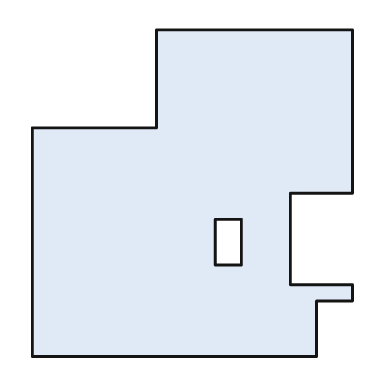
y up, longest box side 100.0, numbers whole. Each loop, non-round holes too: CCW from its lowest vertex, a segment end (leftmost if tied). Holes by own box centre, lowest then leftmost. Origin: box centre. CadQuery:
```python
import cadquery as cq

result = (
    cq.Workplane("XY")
    .moveTo(-49.0, -50.0)
    .lineTo(38.0, -50.0)
    .lineTo(38.0, -33.0)
    .lineTo(49.0, -33.0)
    .lineTo(49.0, -28.0)
    .lineTo(30.0, -28.0)
    .lineTo(30.0, 0.0)
    .lineTo(49.0, 0.0)
    .lineTo(49.0, 50.0)
    .lineTo(-11.0, 50.0)
    .lineTo(-11.0, 20.0)
    .lineTo(-49.0, 20.0)
    .close()
    .moveTo(7.0, -22.0)
    .lineTo(15.0, -22.0)
    .lineTo(15.0, -8.0)
    .lineTo(7.0, -8.0)
    .close()
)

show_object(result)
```